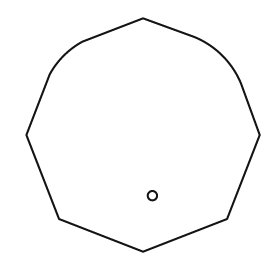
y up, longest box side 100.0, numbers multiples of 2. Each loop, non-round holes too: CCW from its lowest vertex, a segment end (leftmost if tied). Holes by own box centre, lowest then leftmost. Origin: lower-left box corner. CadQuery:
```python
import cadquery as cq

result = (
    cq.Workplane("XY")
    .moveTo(50.0, 0.0)
    .lineTo(86.0, 14.0)
    .lineTo(100.0, 50.0)
    .lineTo(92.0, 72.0)
    .threePointArc((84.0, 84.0), (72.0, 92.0))
    .lineTo(50.0, 100.0)
    .lineTo(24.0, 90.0)
    .threePointArc((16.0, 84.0), (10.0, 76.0))
    .lineTo(0.0, 50.0)
    .lineTo(14.0, 14.0)
    .close()
    .moveTo(54.0, 24.0)
    .circle(2.0)
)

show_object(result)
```